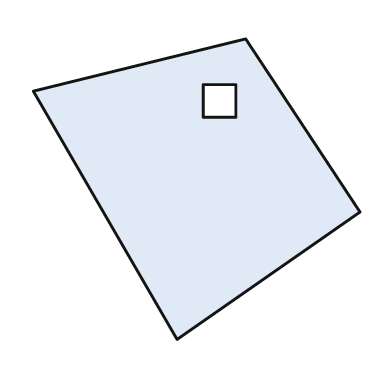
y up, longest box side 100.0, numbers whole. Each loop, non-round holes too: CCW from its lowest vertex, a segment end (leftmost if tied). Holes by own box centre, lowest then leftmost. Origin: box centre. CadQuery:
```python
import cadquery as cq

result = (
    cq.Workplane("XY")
    .moveTo(-6.0, -46.0)
    .lineTo(50.0, -7.0)
    .lineTo(15.0, 46.0)
    .lineTo(-50.0, 30.0)
    .close()
    .moveTo(2.0, 22.0)
    .lineTo(12.0, 22.0)
    .lineTo(12.0, 32.0)
    .lineTo(2.0, 32.0)
    .close()
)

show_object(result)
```